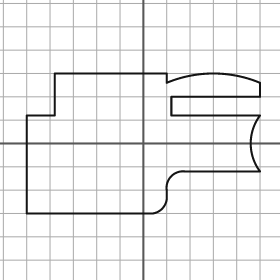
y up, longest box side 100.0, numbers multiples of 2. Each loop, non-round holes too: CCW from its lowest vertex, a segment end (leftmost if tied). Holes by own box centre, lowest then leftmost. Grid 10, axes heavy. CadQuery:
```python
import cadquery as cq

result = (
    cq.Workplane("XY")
    .moveTo(-50.0, -30.0)
    .lineTo(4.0, -30.0)
    .threePointArc((8.0, -28.0), (10.0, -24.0))
    .lineTo(10.0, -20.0)
    .threePointArc((12.0, -14.0), (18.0, -12.0))
    .lineTo(50.0, -12.0)
    .threePointArc((46.0, 0.0), (50.0, 12.0))
    .lineTo(12.0, 12.0)
    .lineTo(12.0, 20.0)
    .lineTo(50.0, 20.0)
    .lineTo(50.0, 26.0)
    .threePointArc((30.0, 30.0), (10.0, 26.0))
    .lineTo(10.0, 30.0)
    .lineTo(-38.0, 30.0)
    .lineTo(-38.0, 12.0)
    .lineTo(-50.0, 12.0)
    .close()
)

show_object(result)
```